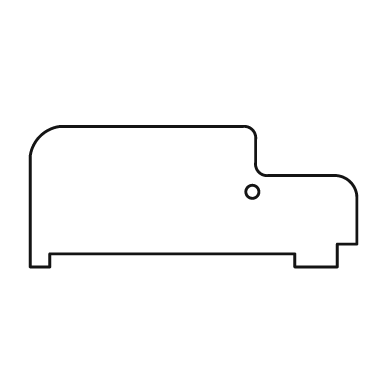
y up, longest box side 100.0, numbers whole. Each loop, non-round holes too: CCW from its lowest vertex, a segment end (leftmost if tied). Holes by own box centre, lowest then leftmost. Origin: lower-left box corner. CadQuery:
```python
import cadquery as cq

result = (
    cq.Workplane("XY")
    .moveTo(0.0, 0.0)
    .lineTo(6.0, 0.0)
    .lineTo(6.0, 4.0)
    .lineTo(81.0, 4.0)
    .lineTo(81.0, 0.0)
    .lineTo(94.0, 0.0)
    .lineTo(94.0, 7.0)
    .lineTo(100.0, 7.0)
    .lineTo(100.0, 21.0)
    .threePointArc((98.0, 26.0), (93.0, 28.0))
    .lineTo(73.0, 28.0)
    .threePointArc((70.0, 29.0), (69.0, 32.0))
    .lineTo(69.0, 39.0)
    .threePointArc((68.0, 42.0), (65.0, 43.0))
    .lineTo(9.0, 43.0)
    .threePointArc((3.0, 40.0), (0.0, 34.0))
    .close()
    .moveTo(68.0, 23.0)
    .circle(2.0)
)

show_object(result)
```